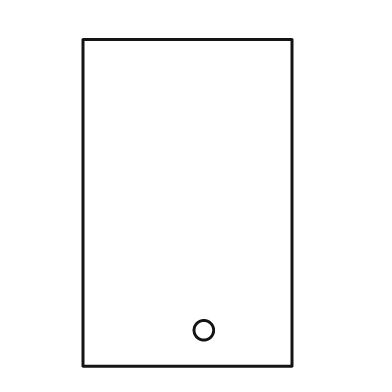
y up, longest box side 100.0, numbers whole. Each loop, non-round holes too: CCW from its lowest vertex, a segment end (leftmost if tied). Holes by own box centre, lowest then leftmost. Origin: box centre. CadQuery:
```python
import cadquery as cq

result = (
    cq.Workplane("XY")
    .moveTo(-32.0, -50.0)
    .lineTo(32.0, -50.0)
    .lineTo(32.0, 50.0)
    .lineTo(-32.0, 50.0)
    .close()
    .moveTo(5.0, -39.0)
    .circle(3.0)
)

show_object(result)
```